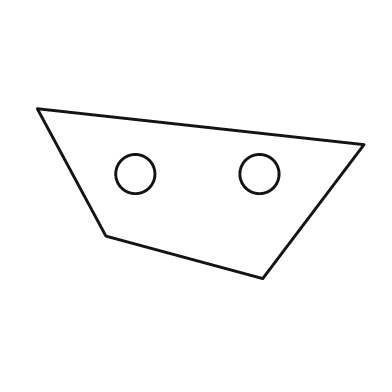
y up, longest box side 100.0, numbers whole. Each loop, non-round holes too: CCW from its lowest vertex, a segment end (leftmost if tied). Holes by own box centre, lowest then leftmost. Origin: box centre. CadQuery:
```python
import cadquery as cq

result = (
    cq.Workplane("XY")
    .moveTo(19.0, -26.0)
    .lineTo(50.0, 15.0)
    .lineTo(-50.0, 26.0)
    .lineTo(-29.0, -13.0)
    .close()
    .moveTo(-20.0, 6.0)
    .circle(6.0)
    .moveTo(18.0, 6.0)
    .circle(6.0)
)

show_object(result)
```